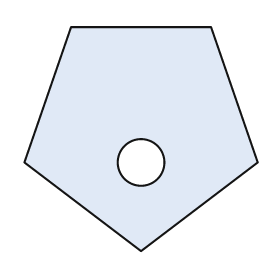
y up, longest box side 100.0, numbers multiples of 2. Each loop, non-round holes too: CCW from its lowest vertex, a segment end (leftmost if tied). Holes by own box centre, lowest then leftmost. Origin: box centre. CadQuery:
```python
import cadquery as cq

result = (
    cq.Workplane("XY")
    .moveTo(0.0, -48.0)
    .lineTo(50.0, -10.0)
    .lineTo(30.0, 48.0)
    .lineTo(-30.0, 48.0)
    .lineTo(-50.0, -10.0)
    .close()
    .moveTo(0.0, -10.0)
    .circle(10.0)
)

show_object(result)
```